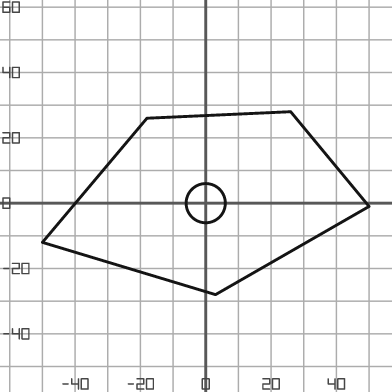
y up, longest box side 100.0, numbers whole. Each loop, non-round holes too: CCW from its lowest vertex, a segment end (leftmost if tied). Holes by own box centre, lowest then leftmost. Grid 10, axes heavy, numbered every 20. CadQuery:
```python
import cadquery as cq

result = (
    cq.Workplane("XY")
    .moveTo(3.0, -28.0)
    .lineTo(50.0, -1.0)
    .lineTo(26.0, 28.0)
    .lineTo(-18.0, 26.0)
    .lineTo(-50.0, -12.0)
    .close()
    .moveTo(0.0, 0.0)
    .circle(6.0)
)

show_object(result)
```